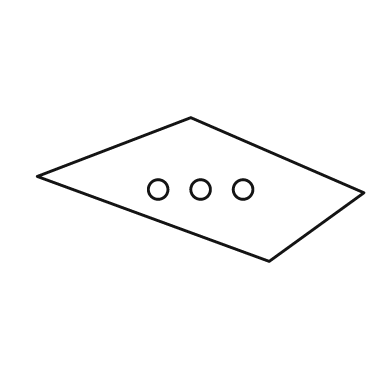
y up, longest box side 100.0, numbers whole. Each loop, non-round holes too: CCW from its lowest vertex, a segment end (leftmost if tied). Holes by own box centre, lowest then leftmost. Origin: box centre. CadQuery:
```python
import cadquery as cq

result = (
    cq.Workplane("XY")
    .moveTo(21.0, -22.0)
    .lineTo(50.0, -1.0)
    .lineTo(-3.0, 22.0)
    .lineTo(-50.0, 4.0)
    .close()
    .moveTo(-13.0, 0.0)
    .circle(3.0)
    .moveTo(0.0, 0.0)
    .circle(3.0)
    .moveTo(13.0, 0.0)
    .circle(3.0)
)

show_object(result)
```